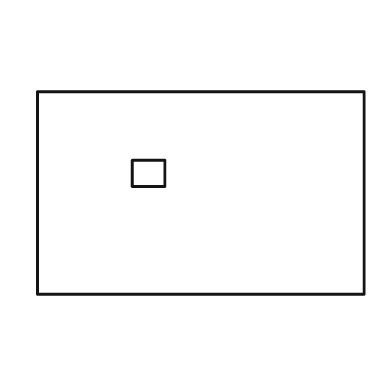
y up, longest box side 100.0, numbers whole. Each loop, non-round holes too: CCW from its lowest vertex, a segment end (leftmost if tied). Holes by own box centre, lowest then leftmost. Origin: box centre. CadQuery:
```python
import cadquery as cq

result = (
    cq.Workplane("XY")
    .moveTo(-50.0, -31.0)
    .lineTo(50.0, -31.0)
    .lineTo(50.0, 31.0)
    .lineTo(-50.0, 31.0)
    .close()
    .moveTo(-21.0, 2.0)
    .lineTo(-11.0, 2.0)
    .lineTo(-11.0, 10.0)
    .lineTo(-21.0, 10.0)
    .close()
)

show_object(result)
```